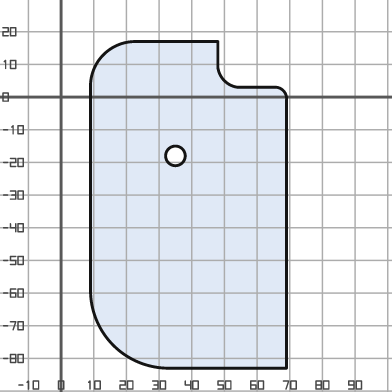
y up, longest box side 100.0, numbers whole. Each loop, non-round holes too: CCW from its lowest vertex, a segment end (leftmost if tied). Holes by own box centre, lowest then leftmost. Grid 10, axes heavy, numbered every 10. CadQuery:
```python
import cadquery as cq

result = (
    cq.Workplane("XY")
    .moveTo(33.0, -83.0)
    .lineTo(69.0, -83.0)
    .lineTo(69.0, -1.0)
    .threePointArc((68.0, 2.0), (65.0, 3.0))
    .lineTo(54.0, 3.0)
    .threePointArc((50.0, 5.0), (48.0, 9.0))
    .lineTo(48.0, 17.0)
    .lineTo(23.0, 17.0)
    .threePointArc((13.0, 13.0), (9.0, 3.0))
    .lineTo(9.0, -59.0)
    .threePointArc((16.0, -76.0), (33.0, -83.0))
    .close()
    .moveTo(35.0, -18.0)
    .circle(3.0)
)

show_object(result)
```